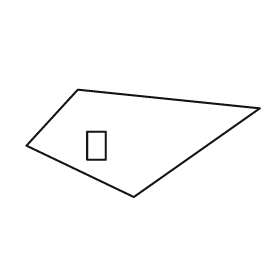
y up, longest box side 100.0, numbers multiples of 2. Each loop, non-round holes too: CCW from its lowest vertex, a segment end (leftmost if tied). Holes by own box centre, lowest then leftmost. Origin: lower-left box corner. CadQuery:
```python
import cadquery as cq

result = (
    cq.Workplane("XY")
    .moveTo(46.0, 0.0)
    .lineTo(100.0, 38.0)
    .lineTo(22.0, 46.0)
    .lineTo(0.0, 22.0)
    .close()
    .moveTo(26.0, 16.0)
    .lineTo(34.0, 16.0)
    .lineTo(34.0, 28.0)
    .lineTo(26.0, 28.0)
    .close()
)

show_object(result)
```